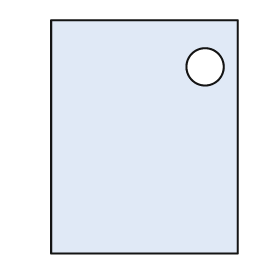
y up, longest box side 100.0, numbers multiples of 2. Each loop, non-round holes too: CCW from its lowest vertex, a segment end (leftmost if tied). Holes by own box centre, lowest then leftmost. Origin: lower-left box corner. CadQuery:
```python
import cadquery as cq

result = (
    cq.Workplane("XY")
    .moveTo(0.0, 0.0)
    .lineTo(80.0, 0.0)
    .lineTo(80.0, 100.0)
    .lineTo(0.0, 100.0)
    .close()
    .moveTo(66.0, 80.0)
    .circle(8.0)
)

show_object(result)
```